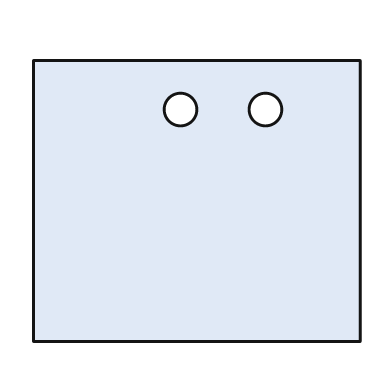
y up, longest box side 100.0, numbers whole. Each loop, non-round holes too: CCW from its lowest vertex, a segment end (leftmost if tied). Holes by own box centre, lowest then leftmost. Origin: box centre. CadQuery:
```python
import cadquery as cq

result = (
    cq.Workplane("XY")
    .moveTo(-50.0, -43.0)
    .lineTo(50.0, -43.0)
    .lineTo(50.0, 43.0)
    .lineTo(-50.0, 43.0)
    .close()
    .moveTo(-5.0, 28.0)
    .circle(5.0)
    .moveTo(21.0, 28.0)
    .circle(5.0)
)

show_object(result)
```